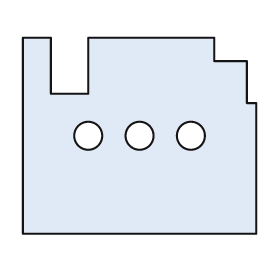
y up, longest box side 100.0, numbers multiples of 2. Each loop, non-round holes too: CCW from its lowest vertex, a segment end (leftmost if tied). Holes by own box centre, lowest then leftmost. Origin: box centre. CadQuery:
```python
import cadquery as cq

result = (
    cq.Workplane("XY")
    .moveTo(-50.0, -42.0)
    .lineTo(50.0, -42.0)
    .lineTo(50.0, 14.0)
    .lineTo(46.0, 14.0)
    .lineTo(46.0, 32.0)
    .lineTo(32.0, 32.0)
    .lineTo(32.0, 42.0)
    .lineTo(-22.0, 42.0)
    .lineTo(-22.0, 18.0)
    .lineTo(-38.0, 18.0)
    .lineTo(-38.0, 42.0)
    .lineTo(-50.0, 42.0)
    .close()
    .moveTo(-22.0, 0.0)
    .circle(6.0)
    .moveTo(0.0, 0.0)
    .circle(6.0)
    .moveTo(22.0, 0.0)
    .circle(6.0)
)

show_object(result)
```